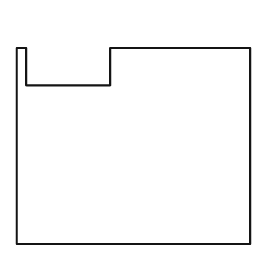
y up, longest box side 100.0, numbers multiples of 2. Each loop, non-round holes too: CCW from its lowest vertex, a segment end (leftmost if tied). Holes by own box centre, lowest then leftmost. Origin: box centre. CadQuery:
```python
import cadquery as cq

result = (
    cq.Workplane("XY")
    .moveTo(-50.0, -42.0)
    .lineTo(50.0, -42.0)
    .lineTo(50.0, 42.0)
    .lineTo(-10.0, 42.0)
    .lineTo(-10.0, 26.0)
    .lineTo(-46.0, 26.0)
    .lineTo(-46.0, 42.0)
    .lineTo(-50.0, 42.0)
    .close()
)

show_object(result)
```